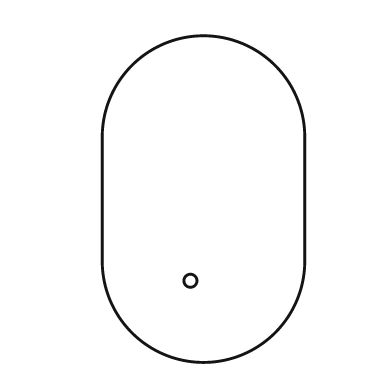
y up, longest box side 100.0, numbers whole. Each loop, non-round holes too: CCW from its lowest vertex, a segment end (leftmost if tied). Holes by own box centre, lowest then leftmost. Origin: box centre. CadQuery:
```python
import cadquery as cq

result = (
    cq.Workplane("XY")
    .moveTo(-31.0, -19.0)
    .threePointArc((0.0, -50.0), (31.0, -19.0))
    .lineTo(31.0, 19.0)
    .threePointArc((0.0, 50.0), (-31.0, 19.0))
    .close()
    .moveTo(-4.0, -25.0)
    .circle(2.0)
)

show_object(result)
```